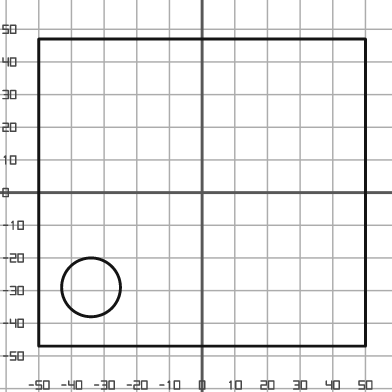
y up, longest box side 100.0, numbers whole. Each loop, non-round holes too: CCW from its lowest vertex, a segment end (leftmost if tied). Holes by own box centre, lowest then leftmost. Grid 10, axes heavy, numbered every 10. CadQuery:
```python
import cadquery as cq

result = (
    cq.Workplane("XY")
    .moveTo(-50.0, -47.0)
    .lineTo(50.0, -47.0)
    .lineTo(50.0, 47.0)
    .lineTo(-50.0, 47.0)
    .close()
    .moveTo(-34.0, -29.0)
    .circle(9.0)
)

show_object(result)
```